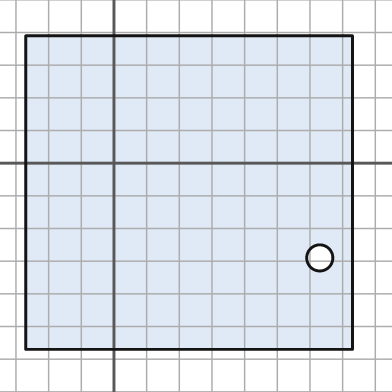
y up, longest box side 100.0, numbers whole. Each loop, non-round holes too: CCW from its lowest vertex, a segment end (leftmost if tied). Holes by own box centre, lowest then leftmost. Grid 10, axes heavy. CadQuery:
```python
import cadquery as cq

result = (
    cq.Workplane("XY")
    .moveTo(-27.0, -57.0)
    .lineTo(73.0, -57.0)
    .lineTo(73.0, 39.0)
    .lineTo(-27.0, 39.0)
    .close()
    .moveTo(63.0, -29.0)
    .circle(4.0)
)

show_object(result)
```